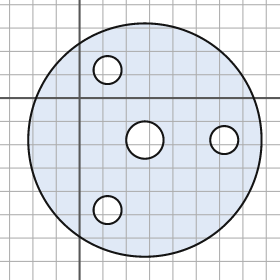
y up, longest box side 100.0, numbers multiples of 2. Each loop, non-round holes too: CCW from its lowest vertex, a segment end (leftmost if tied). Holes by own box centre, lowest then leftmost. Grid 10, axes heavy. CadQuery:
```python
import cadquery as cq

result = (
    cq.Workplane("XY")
    .moveTo(28.0, -18.0)
    .circle(50.0)
    .moveTo(12.0, -48.0)
    .circle(6.0)
    .moveTo(28.0, -18.0)
    .circle(8.0)
    .moveTo(62.0, -18.0)
    .circle(6.0)
    .moveTo(12.0, 12.0)
    .circle(6.0)
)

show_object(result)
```